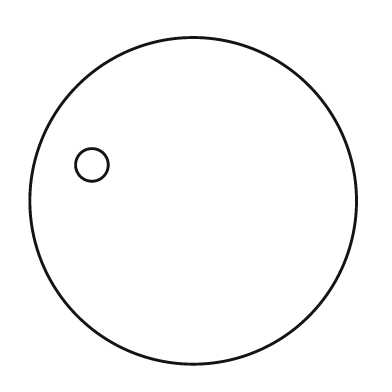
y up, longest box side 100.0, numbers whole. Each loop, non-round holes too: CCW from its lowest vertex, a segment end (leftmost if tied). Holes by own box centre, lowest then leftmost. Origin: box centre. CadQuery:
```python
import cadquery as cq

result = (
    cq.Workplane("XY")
    .moveTo(0.0, 0.0)
    .circle(50.0)
    .moveTo(-31.0, 11.0)
    .circle(5.0)
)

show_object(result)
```